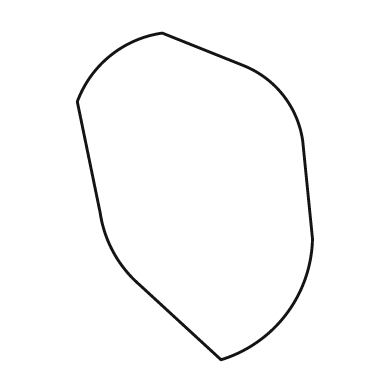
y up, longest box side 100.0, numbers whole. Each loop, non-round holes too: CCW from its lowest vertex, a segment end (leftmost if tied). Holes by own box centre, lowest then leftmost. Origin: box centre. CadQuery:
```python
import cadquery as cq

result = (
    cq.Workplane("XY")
    .moveTo(8.0, -50.0)
    .threePointArc((28.0, -36.0), (36.0, -13.0))
    .lineTo(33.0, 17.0)
    .threePointArc((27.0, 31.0), (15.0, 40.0))
    .lineTo(-10.0, 50.0)
    .threePointArc((-26.0, 43.0), (-36.0, 29.0))
    .lineTo(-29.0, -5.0)
    .threePointArc((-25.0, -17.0), (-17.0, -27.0))
    .close()
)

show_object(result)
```